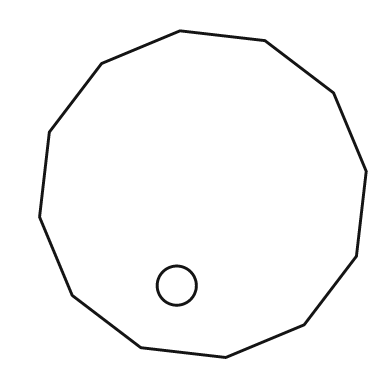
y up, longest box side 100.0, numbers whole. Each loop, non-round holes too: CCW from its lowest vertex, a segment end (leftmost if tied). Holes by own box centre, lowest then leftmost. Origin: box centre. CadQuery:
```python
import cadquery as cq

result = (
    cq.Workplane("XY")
    .moveTo(7.0, -50.0)
    .lineTo(31.0, -40.0)
    .lineTo(47.0, -19.0)
    .lineTo(50.0, 7.0)
    .lineTo(40.0, 31.0)
    .lineTo(19.0, 47.0)
    .lineTo(-7.0, 50.0)
    .lineTo(-31.0, 40.0)
    .lineTo(-47.0, 19.0)
    .lineTo(-50.0, -7.0)
    .lineTo(-40.0, -31.0)
    .lineTo(-19.0, -47.0)
    .close()
    .moveTo(-8.0, -28.0)
    .circle(6.0)
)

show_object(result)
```